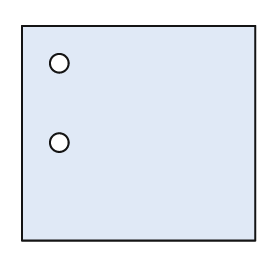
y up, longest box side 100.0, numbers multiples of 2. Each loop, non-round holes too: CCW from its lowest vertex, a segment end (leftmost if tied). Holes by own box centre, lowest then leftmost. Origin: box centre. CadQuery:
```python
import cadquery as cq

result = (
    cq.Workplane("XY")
    .moveTo(-50.0, -46.0)
    .lineTo(50.0, -46.0)
    .lineTo(50.0, 46.0)
    .lineTo(-50.0, 46.0)
    .close()
    .moveTo(-34.0, -4.0)
    .circle(4.0)
    .moveTo(-34.0, 30.0)
    .circle(4.0)
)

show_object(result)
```